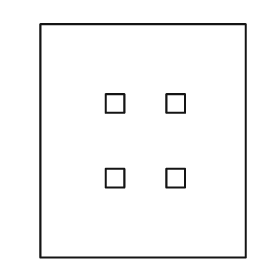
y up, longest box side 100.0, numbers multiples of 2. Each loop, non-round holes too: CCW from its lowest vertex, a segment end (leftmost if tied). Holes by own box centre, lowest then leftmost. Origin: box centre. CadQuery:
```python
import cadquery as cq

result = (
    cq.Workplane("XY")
    .moveTo(-44.0, -50.0)
    .lineTo(44.0, -50.0)
    .lineTo(44.0, 50.0)
    .lineTo(-44.0, 50.0)
    .close()
    .moveTo(-16.0, -20.0)
    .lineTo(-8.0, -20.0)
    .lineTo(-8.0, -12.0)
    .lineTo(-16.0, -12.0)
    .close()
    .moveTo(10.0, -20.0)
    .lineTo(18.0, -20.0)
    .lineTo(18.0, -12.0)
    .lineTo(10.0, -12.0)
    .close()
    .moveTo(-16.0, 12.0)
    .lineTo(-8.0, 12.0)
    .lineTo(-8.0, 20.0)
    .lineTo(-16.0, 20.0)
    .close()
    .moveTo(10.0, 12.0)
    .lineTo(18.0, 12.0)
    .lineTo(18.0, 20.0)
    .lineTo(10.0, 20.0)
    .close()
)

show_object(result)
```